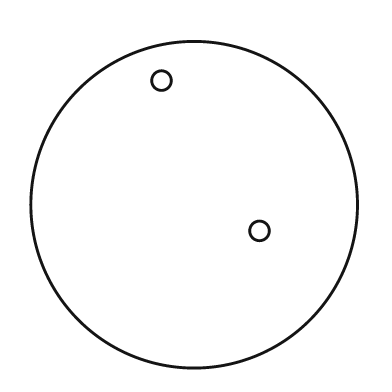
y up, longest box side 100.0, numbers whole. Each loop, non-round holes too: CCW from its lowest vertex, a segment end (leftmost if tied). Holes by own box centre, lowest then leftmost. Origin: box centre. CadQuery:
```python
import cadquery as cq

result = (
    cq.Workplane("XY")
    .moveTo(0.0, 0.0)
    .circle(50.0)
    .moveTo(20.0, -8.0)
    .circle(3.0)
    .moveTo(-10.0, 38.0)
    .circle(3.0)
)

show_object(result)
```